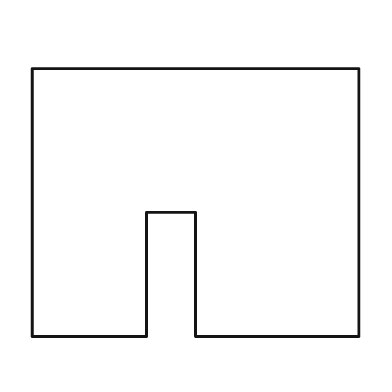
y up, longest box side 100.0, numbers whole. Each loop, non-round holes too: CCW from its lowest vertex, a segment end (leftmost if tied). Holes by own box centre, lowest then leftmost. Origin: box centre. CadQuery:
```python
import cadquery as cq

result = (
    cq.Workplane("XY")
    .moveTo(-50.0, -41.0)
    .lineTo(-15.0, -41.0)
    .lineTo(-15.0, -3.0)
    .lineTo(0.0, -3.0)
    .lineTo(0.0, -41.0)
    .lineTo(50.0, -41.0)
    .lineTo(50.0, 41.0)
    .lineTo(-50.0, 41.0)
    .close()
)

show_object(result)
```